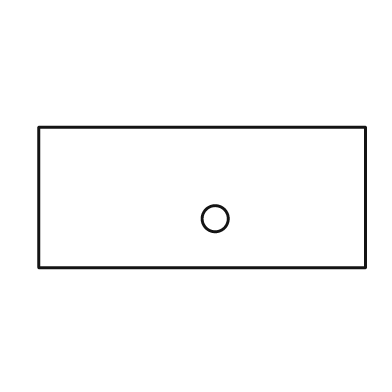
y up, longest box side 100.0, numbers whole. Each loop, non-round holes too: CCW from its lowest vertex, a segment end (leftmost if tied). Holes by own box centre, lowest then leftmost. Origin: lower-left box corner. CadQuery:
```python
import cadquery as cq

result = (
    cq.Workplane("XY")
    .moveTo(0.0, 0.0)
    .lineTo(100.0, 0.0)
    .lineTo(100.0, 43.0)
    .lineTo(0.0, 43.0)
    .close()
    .moveTo(54.0, 15.0)
    .circle(4.0)
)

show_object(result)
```